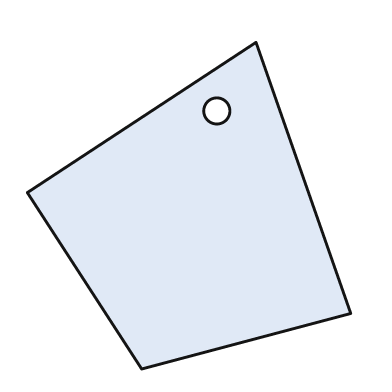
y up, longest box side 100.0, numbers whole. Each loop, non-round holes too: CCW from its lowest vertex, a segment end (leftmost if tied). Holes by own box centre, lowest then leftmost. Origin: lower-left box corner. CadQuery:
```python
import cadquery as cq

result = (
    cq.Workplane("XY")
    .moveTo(35.0, 0.0)
    .lineTo(99.0, 17.0)
    .lineTo(70.0, 100.0)
    .lineTo(0.0, 54.0)
    .close()
    .moveTo(58.0, 79.0)
    .circle(4.0)
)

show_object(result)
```